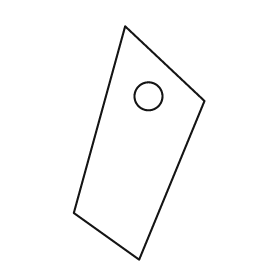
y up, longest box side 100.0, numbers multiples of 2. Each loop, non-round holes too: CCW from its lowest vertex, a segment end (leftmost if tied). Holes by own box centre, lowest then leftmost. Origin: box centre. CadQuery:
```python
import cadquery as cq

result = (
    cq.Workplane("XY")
    .moveTo(0.0, -50.0)
    .lineTo(28.0, 18.0)
    .lineTo(-6.0, 50.0)
    .lineTo(-28.0, -30.0)
    .close()
    .moveTo(4.0, 20.0)
    .circle(6.0)
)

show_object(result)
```